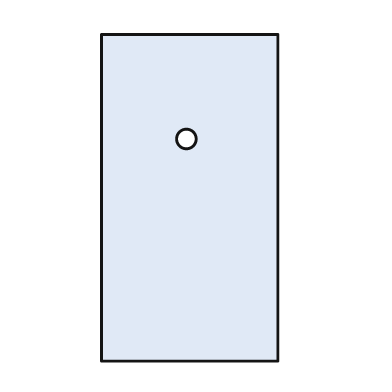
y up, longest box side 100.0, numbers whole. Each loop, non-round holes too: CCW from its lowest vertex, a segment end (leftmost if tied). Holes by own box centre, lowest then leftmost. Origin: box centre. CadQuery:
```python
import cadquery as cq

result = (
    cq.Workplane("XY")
    .moveTo(-27.0, -50.0)
    .lineTo(27.0, -50.0)
    .lineTo(27.0, 50.0)
    .lineTo(-27.0, 50.0)
    .close()
    .moveTo(-1.0, 18.0)
    .circle(3.0)
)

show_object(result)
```